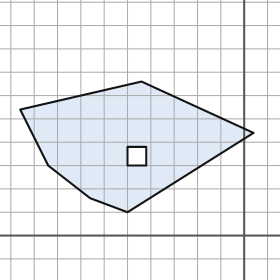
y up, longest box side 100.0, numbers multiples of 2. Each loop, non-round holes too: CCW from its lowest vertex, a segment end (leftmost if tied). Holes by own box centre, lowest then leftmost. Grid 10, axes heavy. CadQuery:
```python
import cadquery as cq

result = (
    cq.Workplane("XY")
    .moveTo(-50.0, 10.0)
    .lineTo(4.0, 44.0)
    .lineTo(-44.0, 66.0)
    .lineTo(-96.0, 54.0)
    .lineTo(-84.0, 30.0)
    .lineTo(-66.0, 16.0)
    .close()
    .moveTo(-50.0, 30.0)
    .lineTo(-42.0, 30.0)
    .lineTo(-42.0, 38.0)
    .lineTo(-50.0, 38.0)
    .close()
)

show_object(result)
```